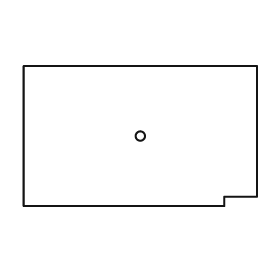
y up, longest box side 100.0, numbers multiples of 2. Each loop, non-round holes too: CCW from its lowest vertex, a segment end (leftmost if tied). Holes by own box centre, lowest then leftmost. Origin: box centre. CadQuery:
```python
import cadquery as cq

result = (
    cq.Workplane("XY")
    .moveTo(-50.0, -30.0)
    .lineTo(36.0, -30.0)
    .lineTo(36.0, -26.0)
    .lineTo(50.0, -26.0)
    .lineTo(50.0, 30.0)
    .lineTo(-50.0, 30.0)
    .close()
    .moveTo(0.0, 0.0)
    .circle(2.0)
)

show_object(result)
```